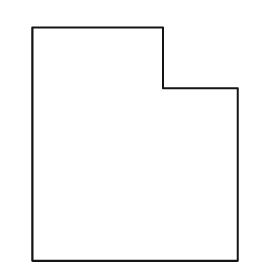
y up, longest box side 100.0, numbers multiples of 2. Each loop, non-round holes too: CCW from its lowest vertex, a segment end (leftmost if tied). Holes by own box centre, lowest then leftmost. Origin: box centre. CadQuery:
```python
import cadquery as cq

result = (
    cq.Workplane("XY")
    .moveTo(-44.0, -50.0)
    .lineTo(44.0, -50.0)
    .lineTo(44.0, 24.0)
    .lineTo(12.0, 24.0)
    .lineTo(12.0, 50.0)
    .lineTo(-44.0, 50.0)
    .close()
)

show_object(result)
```